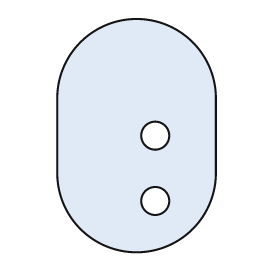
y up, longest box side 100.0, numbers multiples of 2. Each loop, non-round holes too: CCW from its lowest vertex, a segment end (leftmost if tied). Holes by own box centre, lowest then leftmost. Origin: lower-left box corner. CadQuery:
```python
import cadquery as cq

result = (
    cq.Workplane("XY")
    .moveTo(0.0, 34.0)
    .threePointArc((34.0, 0.0), (68.0, 34.0))
    .lineTo(68.0, 66.0)
    .threePointArc((34.0, 100.0), (0.0, 66.0))
    .close()
    .moveTo(42.0, 22.0)
    .circle(6.0)
    .moveTo(42.0, 50.0)
    .circle(6.0)
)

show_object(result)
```